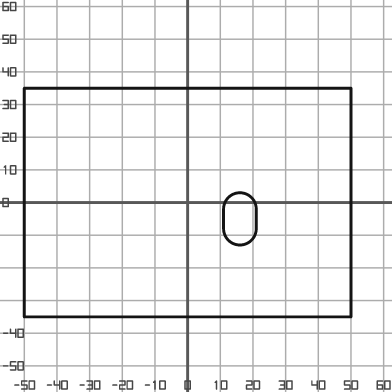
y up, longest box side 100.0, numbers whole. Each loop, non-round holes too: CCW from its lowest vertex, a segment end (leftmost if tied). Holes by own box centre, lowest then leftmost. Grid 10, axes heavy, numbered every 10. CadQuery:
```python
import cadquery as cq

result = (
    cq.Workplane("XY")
    .moveTo(-50.0, -35.0)
    .lineTo(50.0, -35.0)
    .lineTo(50.0, 35.0)
    .lineTo(-50.0, 35.0)
    .close()
    .moveTo(11.0, -8.0)
    .threePointArc((16.0, -13.0), (21.0, -8.0))
    .lineTo(21.0, -2.0)
    .threePointArc((16.0, 3.0), (11.0, -2.0))
    .close()
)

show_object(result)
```